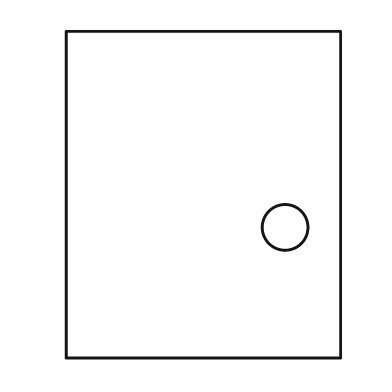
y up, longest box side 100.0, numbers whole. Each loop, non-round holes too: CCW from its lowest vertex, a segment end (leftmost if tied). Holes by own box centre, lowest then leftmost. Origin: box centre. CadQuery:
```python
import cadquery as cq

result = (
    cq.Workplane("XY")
    .moveTo(-42.0, -50.0)
    .lineTo(42.0, -50.0)
    .lineTo(42.0, 50.0)
    .lineTo(-42.0, 50.0)
    .close()
    .moveTo(25.0, -10.0)
    .circle(7.0)
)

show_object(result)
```